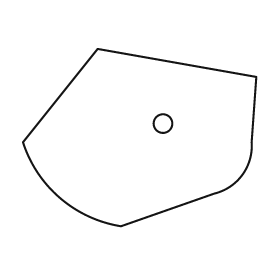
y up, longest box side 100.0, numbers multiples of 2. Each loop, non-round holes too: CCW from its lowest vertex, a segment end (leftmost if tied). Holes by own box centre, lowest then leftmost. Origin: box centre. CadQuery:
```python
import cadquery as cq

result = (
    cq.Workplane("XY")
    .moveTo(-8.0, -38.0)
    .lineTo(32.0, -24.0)
    .threePointArc((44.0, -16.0), (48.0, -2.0))
    .lineTo(50.0, 26.0)
    .lineTo(-18.0, 38.0)
    .lineTo(-50.0, -2.0)
    .threePointArc((-34.0, -26.0), (-8.0, -38.0))
    .close()
    .moveTo(10.0, 6.0)
    .circle(4.0)
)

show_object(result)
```